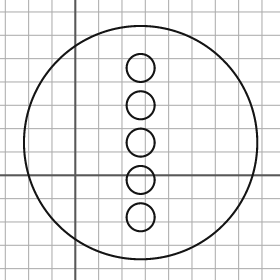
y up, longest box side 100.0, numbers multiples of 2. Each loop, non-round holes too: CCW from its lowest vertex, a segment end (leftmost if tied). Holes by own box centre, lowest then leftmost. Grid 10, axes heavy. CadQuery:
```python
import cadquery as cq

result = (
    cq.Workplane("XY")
    .moveTo(28.0, 14.0)
    .circle(50.0)
    .moveTo(28.0, -18.0)
    .circle(6.0)
    .moveTo(28.0, -2.0)
    .circle(6.0)
    .moveTo(28.0, 14.0)
    .circle(6.0)
    .moveTo(28.0, 30.0)
    .circle(6.0)
    .moveTo(28.0, 46.0)
    .circle(6.0)
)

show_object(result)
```